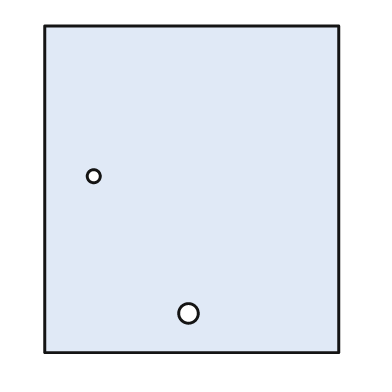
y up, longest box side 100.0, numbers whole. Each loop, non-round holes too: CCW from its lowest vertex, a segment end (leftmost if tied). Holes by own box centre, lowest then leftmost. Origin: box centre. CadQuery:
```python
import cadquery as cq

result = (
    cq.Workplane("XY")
    .moveTo(-45.0, -50.0)
    .lineTo(45.0, -50.0)
    .lineTo(45.0, 50.0)
    .lineTo(-45.0, 50.0)
    .close()
    .moveTo(-1.0, -38.0)
    .circle(3.0)
    .moveTo(-30.0, 4.0)
    .circle(2.0)
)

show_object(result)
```